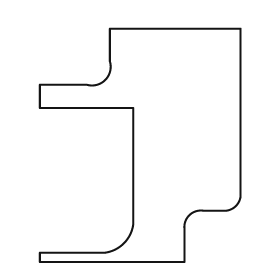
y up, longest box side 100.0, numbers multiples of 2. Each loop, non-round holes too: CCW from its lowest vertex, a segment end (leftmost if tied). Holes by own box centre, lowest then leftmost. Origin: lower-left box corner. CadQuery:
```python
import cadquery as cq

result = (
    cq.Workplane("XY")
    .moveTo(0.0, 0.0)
    .lineTo(62.0, 0.0)
    .lineTo(62.0, 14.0)
    .threePointArc((64.0, 20.0), (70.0, 22.0))
    .lineTo(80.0, 22.0)
    .threePointArc((84.0, 24.0), (86.0, 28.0))
    .lineTo(86.0, 100.0)
    .lineTo(30.0, 100.0)
    .lineTo(30.0, 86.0)
    .threePointArc((28.0, 78.0), (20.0, 76.0))
    .lineTo(0.0, 76.0)
    .lineTo(0.0, 66.0)
    .lineTo(40.0, 66.0)
    .lineTo(40.0, 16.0)
    .threePointArc((36.0, 8.0), (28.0, 4.0))
    .lineTo(0.0, 4.0)
    .close()
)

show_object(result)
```